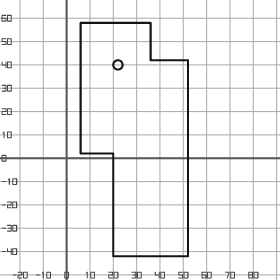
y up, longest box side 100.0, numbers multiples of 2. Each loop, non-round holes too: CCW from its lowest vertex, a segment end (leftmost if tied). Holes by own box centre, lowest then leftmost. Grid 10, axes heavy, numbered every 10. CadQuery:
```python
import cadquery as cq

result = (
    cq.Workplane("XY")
    .moveTo(20.0, -42.0)
    .lineTo(52.0, -42.0)
    .lineTo(52.0, 42.0)
    .lineTo(36.0, 42.0)
    .lineTo(36.0, 58.0)
    .lineTo(6.0, 58.0)
    .lineTo(6.0, 2.0)
    .lineTo(20.0, 2.0)
    .close()
    .moveTo(22.0, 40.0)
    .circle(2.0)
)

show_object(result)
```